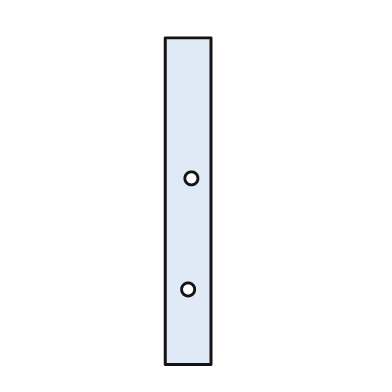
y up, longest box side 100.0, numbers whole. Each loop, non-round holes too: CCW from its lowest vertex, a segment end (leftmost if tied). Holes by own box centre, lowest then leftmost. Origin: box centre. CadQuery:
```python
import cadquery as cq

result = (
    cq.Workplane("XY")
    .moveTo(-7.0, -50.0)
    .lineTo(7.0, -50.0)
    .lineTo(7.0, 50.0)
    .lineTo(-7.0, 50.0)
    .close()
    .moveTo(0.0, -27.0)
    .circle(2.0)
    .moveTo(1.0, 7.0)
    .circle(2.0)
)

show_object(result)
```